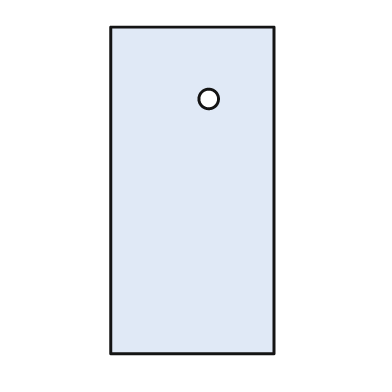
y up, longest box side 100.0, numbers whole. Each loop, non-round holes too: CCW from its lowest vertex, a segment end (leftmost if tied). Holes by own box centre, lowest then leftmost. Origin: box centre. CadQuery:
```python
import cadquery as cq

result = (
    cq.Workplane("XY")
    .moveTo(-25.0, -50.0)
    .lineTo(25.0, -50.0)
    .lineTo(25.0, 50.0)
    .lineTo(-25.0, 50.0)
    .close()
    .moveTo(5.0, 28.0)
    .circle(3.0)
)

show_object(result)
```